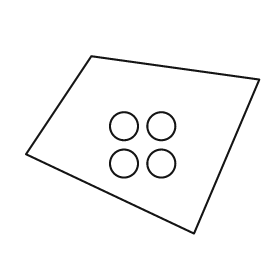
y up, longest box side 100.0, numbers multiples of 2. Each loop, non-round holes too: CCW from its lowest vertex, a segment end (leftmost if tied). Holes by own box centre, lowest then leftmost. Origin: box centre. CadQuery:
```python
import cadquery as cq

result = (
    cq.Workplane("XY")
    .moveTo(22.0, -38.0)
    .lineTo(50.0, 28.0)
    .lineTo(-22.0, 38.0)
    .lineTo(-50.0, -4.0)
    .close()
    .moveTo(-8.0, -8.0)
    .circle(6.0)
    .moveTo(8.0, -8.0)
    .circle(6.0)
    .moveTo(-8.0, 8.0)
    .circle(6.0)
    .moveTo(8.0, 8.0)
    .circle(6.0)
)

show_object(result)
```